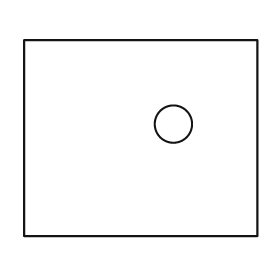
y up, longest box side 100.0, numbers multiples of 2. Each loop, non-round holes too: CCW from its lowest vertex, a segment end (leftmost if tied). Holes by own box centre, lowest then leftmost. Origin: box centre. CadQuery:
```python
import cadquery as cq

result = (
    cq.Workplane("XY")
    .moveTo(-50.0, -42.0)
    .lineTo(50.0, -42.0)
    .lineTo(50.0, 42.0)
    .lineTo(-50.0, 42.0)
    .close()
    .moveTo(14.0, 6.0)
    .circle(8.0)
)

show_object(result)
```